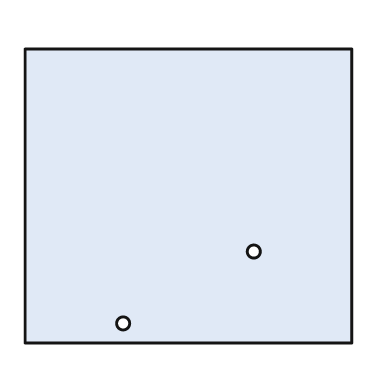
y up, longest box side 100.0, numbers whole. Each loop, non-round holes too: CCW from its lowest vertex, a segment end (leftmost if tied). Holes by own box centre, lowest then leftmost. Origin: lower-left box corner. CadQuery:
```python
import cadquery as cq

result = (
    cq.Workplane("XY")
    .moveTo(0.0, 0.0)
    .lineTo(100.0, 0.0)
    .lineTo(100.0, 90.0)
    .lineTo(0.0, 90.0)
    .close()
    .moveTo(30.0, 6.0)
    .circle(2.0)
    .moveTo(70.0, 28.0)
    .circle(2.0)
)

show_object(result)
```